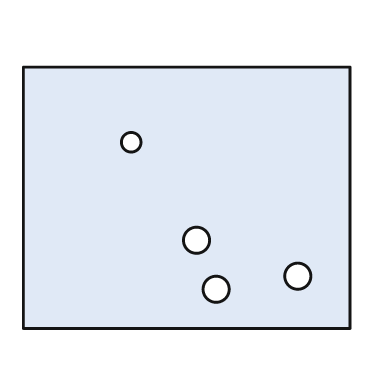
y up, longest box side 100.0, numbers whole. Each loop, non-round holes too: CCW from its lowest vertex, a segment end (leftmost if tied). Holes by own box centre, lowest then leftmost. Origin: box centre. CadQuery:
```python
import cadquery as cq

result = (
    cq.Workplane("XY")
    .moveTo(-50.0, -40.0)
    .lineTo(50.0, -40.0)
    .lineTo(50.0, 40.0)
    .lineTo(-50.0, 40.0)
    .close()
    .moveTo(9.0, -28.0)
    .circle(4.0)
    .moveTo(34.0, -24.0)
    .circle(4.0)
    .moveTo(3.0, -13.0)
    .circle(4.0)
    .moveTo(-17.0, 17.0)
    .circle(3.0)
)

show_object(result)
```